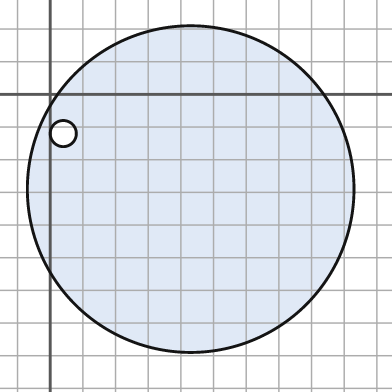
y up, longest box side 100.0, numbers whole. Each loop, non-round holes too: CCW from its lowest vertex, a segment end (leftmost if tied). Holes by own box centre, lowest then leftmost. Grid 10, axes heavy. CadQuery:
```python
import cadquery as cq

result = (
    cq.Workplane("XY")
    .moveTo(43.0, -29.0)
    .circle(50.0)
    .moveTo(4.0, -12.0)
    .circle(4.0)
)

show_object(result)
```